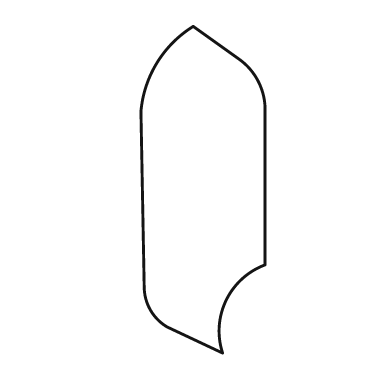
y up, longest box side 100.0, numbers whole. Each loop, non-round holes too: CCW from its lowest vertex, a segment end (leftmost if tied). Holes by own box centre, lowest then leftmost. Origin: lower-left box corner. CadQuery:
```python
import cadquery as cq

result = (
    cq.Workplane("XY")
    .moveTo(25.0, 0.0)
    .threePointArc((26.0, 16.0), (38.0, 27.0))
    .lineTo(38.0, 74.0)
    .threePointArc((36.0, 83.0), (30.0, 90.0))
    .lineTo(16.0, 100.0)
    .threePointArc((5.0, 89.0), (0.0, 74.0))
    .lineTo(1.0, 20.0)
    .threePointArc((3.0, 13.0), (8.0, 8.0))
    .close()
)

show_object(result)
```